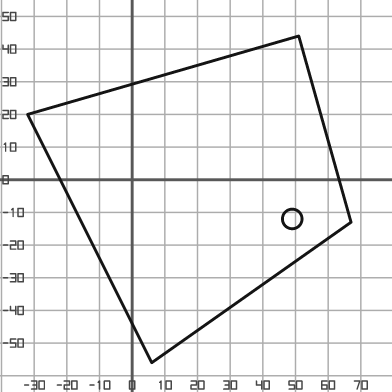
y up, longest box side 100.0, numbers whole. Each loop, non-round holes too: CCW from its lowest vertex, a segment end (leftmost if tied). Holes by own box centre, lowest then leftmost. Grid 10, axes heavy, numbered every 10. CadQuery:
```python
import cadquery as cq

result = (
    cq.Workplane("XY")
    .moveTo(6.0, -56.0)
    .lineTo(67.0, -13.0)
    .lineTo(51.0, 44.0)
    .lineTo(-32.0, 20.0)
    .close()
    .moveTo(49.0, -12.0)
    .circle(3.0)
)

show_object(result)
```